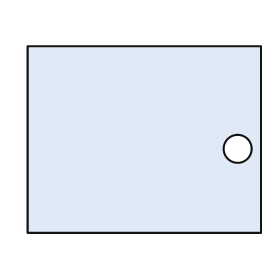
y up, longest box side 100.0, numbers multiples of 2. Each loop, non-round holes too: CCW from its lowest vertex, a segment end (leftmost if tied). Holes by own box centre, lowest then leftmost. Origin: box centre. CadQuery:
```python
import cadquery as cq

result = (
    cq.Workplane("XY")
    .moveTo(-50.0, -40.0)
    .lineTo(50.0, -40.0)
    .lineTo(50.0, 40.0)
    .lineTo(-50.0, 40.0)
    .close()
    .moveTo(40.0, -4.0)
    .circle(6.0)
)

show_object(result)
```